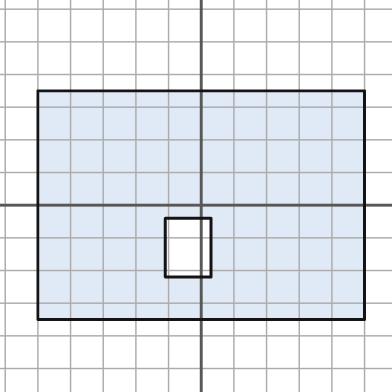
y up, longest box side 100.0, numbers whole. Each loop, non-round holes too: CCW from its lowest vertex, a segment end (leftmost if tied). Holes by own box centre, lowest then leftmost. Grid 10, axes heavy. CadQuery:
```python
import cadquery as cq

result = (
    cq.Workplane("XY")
    .moveTo(-50.0, -35.0)
    .lineTo(50.0, -35.0)
    .lineTo(50.0, 35.0)
    .lineTo(-50.0, 35.0)
    .close()
    .moveTo(-11.0, -22.0)
    .lineTo(3.0, -22.0)
    .lineTo(3.0, -4.0)
    .lineTo(-11.0, -4.0)
    .close()
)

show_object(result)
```